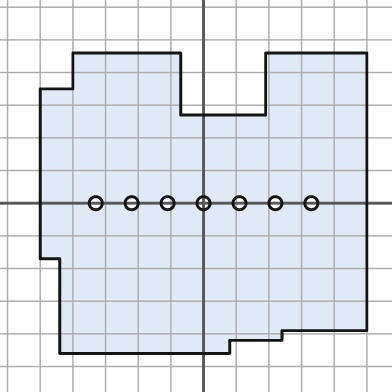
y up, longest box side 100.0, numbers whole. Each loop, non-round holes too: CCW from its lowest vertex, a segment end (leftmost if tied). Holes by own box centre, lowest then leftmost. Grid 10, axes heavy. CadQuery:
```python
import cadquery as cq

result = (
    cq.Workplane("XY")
    .moveTo(-44.0, -46.0)
    .lineTo(8.0, -46.0)
    .lineTo(8.0, -42.0)
    .lineTo(24.0, -42.0)
    .lineTo(24.0, -39.0)
    .lineTo(50.0, -39.0)
    .lineTo(50.0, 46.0)
    .lineTo(19.0, 46.0)
    .lineTo(19.0, 27.0)
    .lineTo(-7.0, 27.0)
    .lineTo(-7.0, 46.0)
    .lineTo(-40.0, 46.0)
    .lineTo(-40.0, 35.0)
    .lineTo(-50.0, 35.0)
    .lineTo(-50.0, -17.0)
    .lineTo(-44.0, -17.0)
    .close()
    .moveTo(-33.0, 0.0)
    .circle(2.0)
    .moveTo(-22.0, 0.0)
    .circle(2.0)
    .moveTo(-11.0, 0.0)
    .circle(2.0)
    .moveTo(0.0, 0.0)
    .circle(2.0)
    .moveTo(11.0, 0.0)
    .circle(2.0)
    .moveTo(22.0, 0.0)
    .circle(2.0)
    .moveTo(33.0, 0.0)
    .circle(2.0)
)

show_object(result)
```